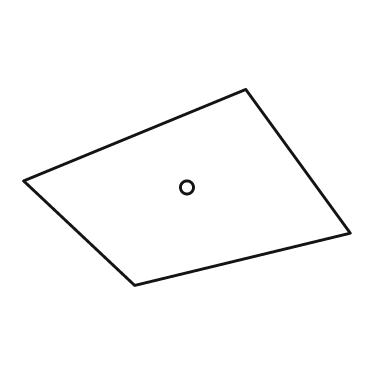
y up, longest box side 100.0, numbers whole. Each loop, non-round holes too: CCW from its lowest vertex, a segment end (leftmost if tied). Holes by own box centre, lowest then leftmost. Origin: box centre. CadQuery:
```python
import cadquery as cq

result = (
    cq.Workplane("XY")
    .moveTo(-16.0, -30.0)
    .lineTo(50.0, -14.0)
    .lineTo(18.0, 30.0)
    .lineTo(-50.0, 2.0)
    .close()
    .moveTo(0.0, 0.0)
    .circle(2.0)
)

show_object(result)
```